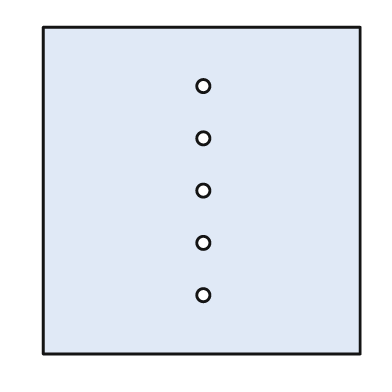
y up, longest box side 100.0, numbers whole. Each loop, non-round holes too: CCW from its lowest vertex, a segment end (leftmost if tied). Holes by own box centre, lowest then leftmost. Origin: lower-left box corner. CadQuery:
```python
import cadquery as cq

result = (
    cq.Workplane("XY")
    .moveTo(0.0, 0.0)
    .lineTo(97.0, 0.0)
    .lineTo(97.0, 100.0)
    .lineTo(0.0, 100.0)
    .close()
    .moveTo(49.0, 18.0)
    .circle(2.0)
    .moveTo(49.0, 34.0)
    .circle(2.0)
    .moveTo(49.0, 50.0)
    .circle(2.0)
    .moveTo(49.0, 66.0)
    .circle(2.0)
    .moveTo(49.0, 82.0)
    .circle(2.0)
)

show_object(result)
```